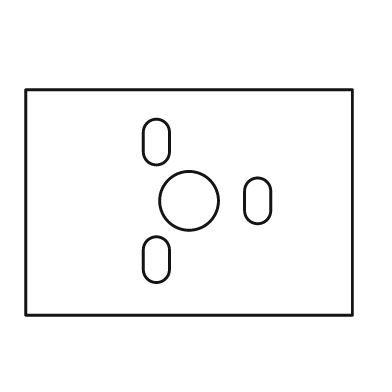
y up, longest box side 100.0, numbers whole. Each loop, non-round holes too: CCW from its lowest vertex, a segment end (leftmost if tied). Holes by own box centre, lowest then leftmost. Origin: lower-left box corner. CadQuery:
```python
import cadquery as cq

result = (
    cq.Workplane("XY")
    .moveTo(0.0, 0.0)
    .lineTo(100.0, 0.0)
    .lineTo(100.0, 69.0)
    .lineTo(0.0, 69.0)
    .close()
    .moveTo(36.0, 14.0)
    .threePointArc((40.0, 10.0), (44.0, 14.0))
    .lineTo(44.0, 20.0)
    .threePointArc((40.0, 24.0), (36.0, 20.0))
    .close()
    .moveTo(50.0, 35.0)
    .circle(9.0)
    .moveTo(67.0, 32.0)
    .threePointArc((71.0, 28.0), (75.0, 32.0))
    .lineTo(75.0, 38.0)
    .threePointArc((71.0, 42.0), (67.0, 38.0))
    .close()
    .moveTo(36.0, 50.0)
    .threePointArc((40.0, 46.0), (44.0, 50.0))
    .lineTo(44.0, 56.0)
    .threePointArc((40.0, 60.0), (36.0, 56.0))
    .close()
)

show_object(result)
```